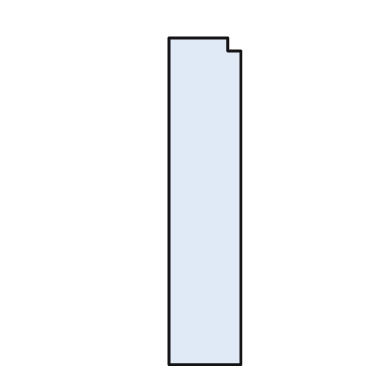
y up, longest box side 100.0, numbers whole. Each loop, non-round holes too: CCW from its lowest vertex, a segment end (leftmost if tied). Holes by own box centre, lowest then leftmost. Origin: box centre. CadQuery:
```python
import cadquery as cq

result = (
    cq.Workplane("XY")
    .moveTo(-11.0, -50.0)
    .lineTo(11.0, -50.0)
    .lineTo(11.0, 46.0)
    .lineTo(7.0, 46.0)
    .lineTo(7.0, 50.0)
    .lineTo(-11.0, 50.0)
    .close()
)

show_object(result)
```